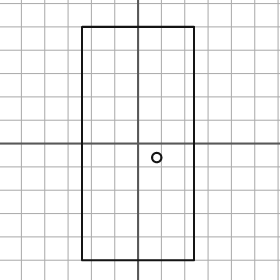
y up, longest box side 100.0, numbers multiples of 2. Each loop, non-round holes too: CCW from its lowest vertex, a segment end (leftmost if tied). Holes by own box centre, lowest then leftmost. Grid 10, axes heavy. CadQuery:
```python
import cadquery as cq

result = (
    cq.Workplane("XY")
    .moveTo(-24.0, -50.0)
    .lineTo(24.0, -50.0)
    .lineTo(24.0, 50.0)
    .lineTo(-24.0, 50.0)
    .close()
    .moveTo(8.0, -6.0)
    .circle(2.0)
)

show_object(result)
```